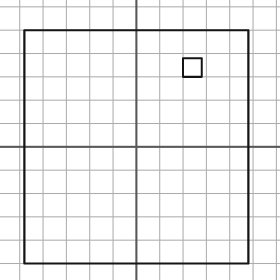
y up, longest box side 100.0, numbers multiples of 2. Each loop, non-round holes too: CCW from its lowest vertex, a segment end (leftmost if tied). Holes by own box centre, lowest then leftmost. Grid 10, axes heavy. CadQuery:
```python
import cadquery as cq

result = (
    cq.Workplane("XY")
    .moveTo(-48.0, -50.0)
    .lineTo(48.0, -50.0)
    .lineTo(48.0, 50.0)
    .lineTo(-48.0, 50.0)
    .close()
    .moveTo(20.0, 30.0)
    .lineTo(28.0, 30.0)
    .lineTo(28.0, 38.0)
    .lineTo(20.0, 38.0)
    .close()
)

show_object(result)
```